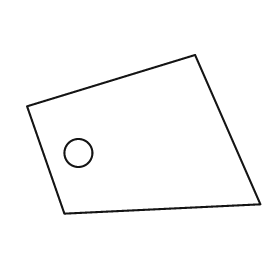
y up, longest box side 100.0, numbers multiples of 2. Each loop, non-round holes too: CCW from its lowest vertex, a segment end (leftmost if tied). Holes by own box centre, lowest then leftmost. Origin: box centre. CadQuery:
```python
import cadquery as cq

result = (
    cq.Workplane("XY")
    .moveTo(-34.0, -34.0)
    .lineTo(50.0, -30.0)
    .lineTo(22.0, 34.0)
    .lineTo(-50.0, 12.0)
    .close()
    .moveTo(-28.0, -8.0)
    .circle(6.0)
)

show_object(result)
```